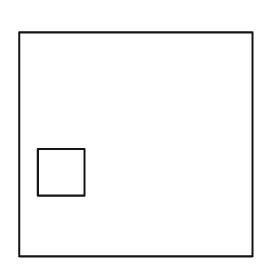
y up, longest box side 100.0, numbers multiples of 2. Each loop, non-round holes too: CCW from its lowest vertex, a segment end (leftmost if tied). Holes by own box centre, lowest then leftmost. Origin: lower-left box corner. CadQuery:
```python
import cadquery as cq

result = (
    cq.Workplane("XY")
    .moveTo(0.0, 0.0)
    .lineTo(100.0, 0.0)
    .lineTo(100.0, 96.0)
    .lineTo(0.0, 96.0)
    .close()
    .moveTo(8.0, 26.0)
    .lineTo(28.0, 26.0)
    .lineTo(28.0, 46.0)
    .lineTo(8.0, 46.0)
    .close()
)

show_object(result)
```